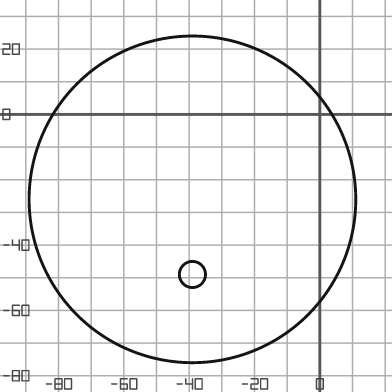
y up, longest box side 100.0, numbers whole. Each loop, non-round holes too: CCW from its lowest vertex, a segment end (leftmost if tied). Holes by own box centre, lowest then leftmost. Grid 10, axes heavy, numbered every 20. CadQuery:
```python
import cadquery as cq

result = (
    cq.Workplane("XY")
    .moveTo(-39.0, -26.0)
    .circle(50.0)
    .moveTo(-39.0, -49.0)
    .circle(4.0)
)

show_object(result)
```